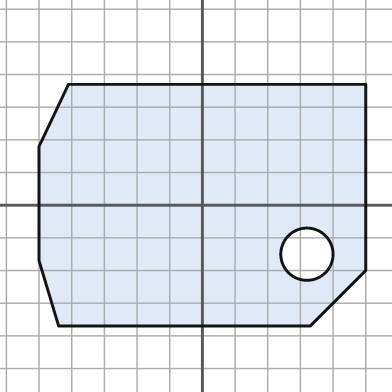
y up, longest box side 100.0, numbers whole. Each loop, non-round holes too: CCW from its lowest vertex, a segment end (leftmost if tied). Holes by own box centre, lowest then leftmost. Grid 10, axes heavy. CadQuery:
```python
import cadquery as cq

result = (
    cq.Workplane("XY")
    .moveTo(-44.0, -37.0)
    .lineTo(33.0, -37.0)
    .lineTo(50.0, -20.0)
    .lineTo(50.0, 37.0)
    .lineTo(-41.0, 37.0)
    .lineTo(-50.0, 18.0)
    .lineTo(-50.0, -17.0)
    .close()
    .moveTo(32.0, -15.0)
    .circle(8.0)
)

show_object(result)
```